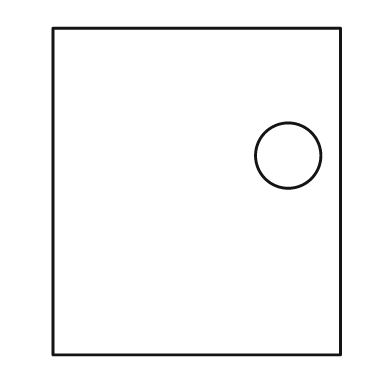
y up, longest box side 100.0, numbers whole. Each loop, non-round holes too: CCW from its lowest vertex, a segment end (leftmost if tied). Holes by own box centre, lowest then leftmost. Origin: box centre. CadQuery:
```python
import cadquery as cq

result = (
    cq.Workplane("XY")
    .moveTo(-44.0, -50.0)
    .lineTo(44.0, -50.0)
    .lineTo(44.0, 50.0)
    .lineTo(-44.0, 50.0)
    .close()
    .moveTo(28.0, 11.0)
    .circle(10.0)
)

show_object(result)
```